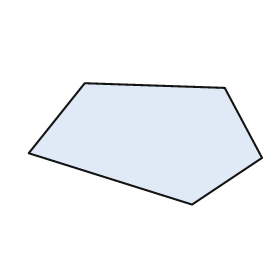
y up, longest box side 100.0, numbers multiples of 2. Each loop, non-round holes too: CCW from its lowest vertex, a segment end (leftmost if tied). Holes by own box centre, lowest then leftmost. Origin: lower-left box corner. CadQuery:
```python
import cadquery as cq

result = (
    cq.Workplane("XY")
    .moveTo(70.0, 0.0)
    .lineTo(100.0, 20.0)
    .lineTo(84.0, 50.0)
    .lineTo(24.0, 52.0)
    .lineTo(0.0, 22.0)
    .close()
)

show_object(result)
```